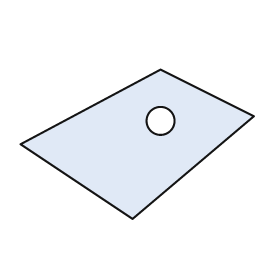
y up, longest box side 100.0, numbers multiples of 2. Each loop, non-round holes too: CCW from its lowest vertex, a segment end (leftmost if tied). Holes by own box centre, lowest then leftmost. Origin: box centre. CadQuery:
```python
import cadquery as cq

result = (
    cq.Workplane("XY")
    .moveTo(-2.0, -32.0)
    .lineTo(50.0, 12.0)
    .lineTo(10.0, 32.0)
    .lineTo(-50.0, 0.0)
    .close()
    .moveTo(10.0, 10.0)
    .circle(6.0)
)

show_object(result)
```